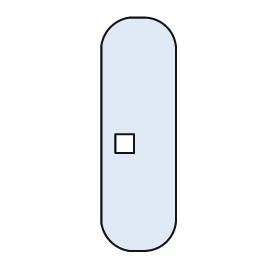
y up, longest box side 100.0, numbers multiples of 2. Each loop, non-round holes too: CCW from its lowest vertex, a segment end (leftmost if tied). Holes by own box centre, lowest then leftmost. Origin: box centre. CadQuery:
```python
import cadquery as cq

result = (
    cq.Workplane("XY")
    .moveTo(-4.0, -50.0)
    .lineTo(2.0, -50.0)
    .threePointArc((12.0, -46.0), (16.0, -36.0))
    .lineTo(16.0, 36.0)
    .threePointArc((12.0, 46.0), (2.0, 50.0))
    .lineTo(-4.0, 50.0)
    .threePointArc((-12.0, 46.0), (-16.0, 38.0))
    .lineTo(-16.0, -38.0)
    .threePointArc((-12.0, -46.0), (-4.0, -50.0))
    .close()
    .moveTo(-10.0, -8.0)
    .lineTo(-2.0, -8.0)
    .lineTo(-2.0, 0.0)
    .lineTo(-10.0, 0.0)
    .close()
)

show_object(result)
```